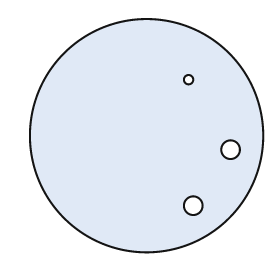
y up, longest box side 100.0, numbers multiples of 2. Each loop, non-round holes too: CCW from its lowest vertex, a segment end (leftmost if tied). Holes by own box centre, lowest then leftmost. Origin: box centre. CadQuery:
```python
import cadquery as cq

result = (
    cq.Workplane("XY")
    .moveTo(0.0, 0.0)
    .circle(50.0)
    .moveTo(20.0, -30.0)
    .circle(4.0)
    .moveTo(36.0, -6.0)
    .circle(4.0)
    .moveTo(18.0, 24.0)
    .circle(2.0)
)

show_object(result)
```